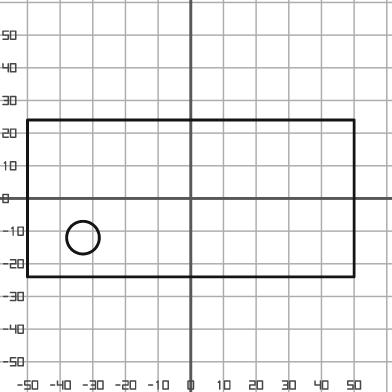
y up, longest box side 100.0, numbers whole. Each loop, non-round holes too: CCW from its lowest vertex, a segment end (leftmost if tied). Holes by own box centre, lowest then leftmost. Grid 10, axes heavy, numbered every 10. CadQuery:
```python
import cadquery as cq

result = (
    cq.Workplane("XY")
    .moveTo(-50.0, -24.0)
    .lineTo(50.0, -24.0)
    .lineTo(50.0, 24.0)
    .lineTo(-50.0, 24.0)
    .close()
    .moveTo(-33.0, -12.0)
    .circle(5.0)
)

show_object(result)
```